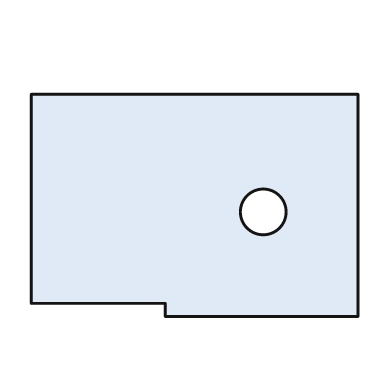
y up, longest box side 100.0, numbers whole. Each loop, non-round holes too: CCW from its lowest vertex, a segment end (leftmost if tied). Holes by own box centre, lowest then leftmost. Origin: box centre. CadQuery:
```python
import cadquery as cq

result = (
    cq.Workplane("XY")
    .moveTo(-9.0, -34.0)
    .lineTo(50.0, -34.0)
    .lineTo(50.0, 34.0)
    .lineTo(-50.0, 34.0)
    .lineTo(-50.0, -30.0)
    .lineTo(-9.0, -30.0)
    .close()
    .moveTo(21.0, -2.0)
    .circle(7.0)
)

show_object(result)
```